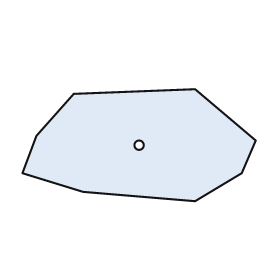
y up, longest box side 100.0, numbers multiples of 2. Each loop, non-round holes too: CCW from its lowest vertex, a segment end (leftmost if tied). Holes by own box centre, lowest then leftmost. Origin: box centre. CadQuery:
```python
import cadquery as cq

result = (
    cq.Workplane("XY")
    .moveTo(24.0, -24.0)
    .lineTo(44.0, -12.0)
    .lineTo(50.0, 2.0)
    .lineTo(24.0, 24.0)
    .lineTo(-28.0, 22.0)
    .lineTo(-44.0, 4.0)
    .lineTo(-50.0, -12.0)
    .lineTo(-24.0, -20.0)
    .close()
    .moveTo(0.0, 0.0)
    .circle(2.0)
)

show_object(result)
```